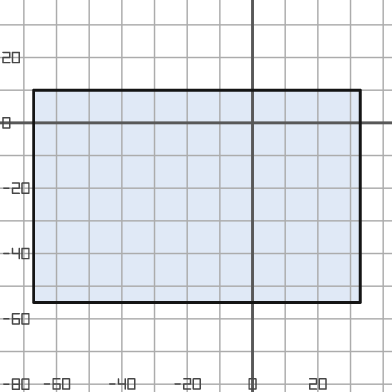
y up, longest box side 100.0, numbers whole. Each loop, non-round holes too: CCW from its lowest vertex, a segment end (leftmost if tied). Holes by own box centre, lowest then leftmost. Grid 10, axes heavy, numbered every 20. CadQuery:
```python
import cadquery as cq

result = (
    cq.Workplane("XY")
    .moveTo(-67.0, -55.0)
    .lineTo(33.0, -55.0)
    .lineTo(33.0, 10.0)
    .lineTo(-67.0, 10.0)
    .close()
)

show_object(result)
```